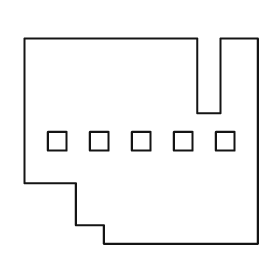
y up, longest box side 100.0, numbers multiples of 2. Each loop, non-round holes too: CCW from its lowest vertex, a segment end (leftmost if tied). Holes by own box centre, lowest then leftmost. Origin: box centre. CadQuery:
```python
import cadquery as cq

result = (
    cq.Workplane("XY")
    .moveTo(-16.0, -44.0)
    .lineTo(50.0, -44.0)
    .lineTo(50.0, 44.0)
    .lineTo(34.0, 44.0)
    .lineTo(34.0, 12.0)
    .lineTo(24.0, 12.0)
    .lineTo(24.0, 44.0)
    .lineTo(-50.0, 44.0)
    .lineTo(-50.0, -18.0)
    .lineTo(-28.0, -18.0)
    .lineTo(-28.0, -36.0)
    .lineTo(-16.0, -36.0)
    .close()
    .moveTo(-40.0, -4.0)
    .lineTo(-32.0, -4.0)
    .lineTo(-32.0, 4.0)
    .lineTo(-40.0, 4.0)
    .close()
    .moveTo(-22.0, -4.0)
    .lineTo(-14.0, -4.0)
    .lineTo(-14.0, 4.0)
    .lineTo(-22.0, 4.0)
    .close()
    .moveTo(-4.0, -4.0)
    .lineTo(4.0, -4.0)
    .lineTo(4.0, 4.0)
    .lineTo(-4.0, 4.0)
    .close()
    .moveTo(14.0, -4.0)
    .lineTo(22.0, -4.0)
    .lineTo(22.0, 4.0)
    .lineTo(14.0, 4.0)
    .close()
    .moveTo(32.0, -4.0)
    .lineTo(40.0, -4.0)
    .lineTo(40.0, 4.0)
    .lineTo(32.0, 4.0)
    .close()
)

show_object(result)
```